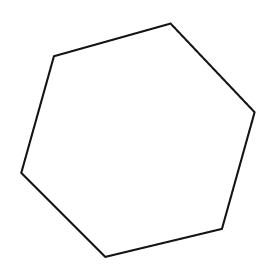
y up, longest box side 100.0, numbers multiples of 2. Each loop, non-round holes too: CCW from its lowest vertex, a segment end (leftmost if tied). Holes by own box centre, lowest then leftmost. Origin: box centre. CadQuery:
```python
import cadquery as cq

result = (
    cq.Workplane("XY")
    .moveTo(-14.0, -50.0)
    .lineTo(36.0, -38.0)
    .lineTo(50.0, 12.0)
    .lineTo(14.0, 50.0)
    .lineTo(-36.0, 36.0)
    .lineTo(-50.0, -14.0)
    .close()
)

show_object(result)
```